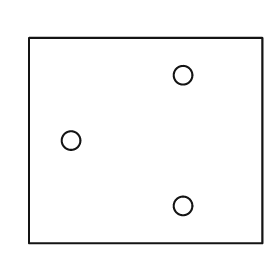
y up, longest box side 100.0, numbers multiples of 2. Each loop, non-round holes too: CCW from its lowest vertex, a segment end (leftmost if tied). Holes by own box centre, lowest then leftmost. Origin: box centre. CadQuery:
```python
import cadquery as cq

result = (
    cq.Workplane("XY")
    .moveTo(-50.0, -44.0)
    .lineTo(50.0, -44.0)
    .lineTo(50.0, 44.0)
    .lineTo(-50.0, 44.0)
    .close()
    .moveTo(16.0, -28.0)
    .circle(4.0)
    .moveTo(-32.0, 0.0)
    .circle(4.0)
    .moveTo(16.0, 28.0)
    .circle(4.0)
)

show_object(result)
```